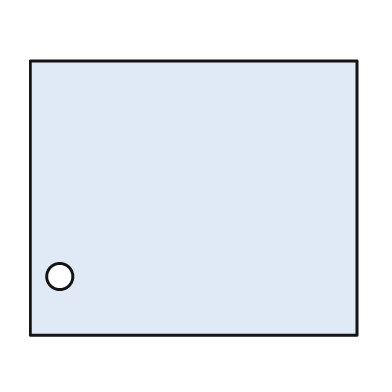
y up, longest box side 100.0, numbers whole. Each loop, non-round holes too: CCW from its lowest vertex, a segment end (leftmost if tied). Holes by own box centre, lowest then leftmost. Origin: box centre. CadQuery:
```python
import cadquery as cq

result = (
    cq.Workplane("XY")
    .moveTo(-50.0, -42.0)
    .lineTo(50.0, -42.0)
    .lineTo(50.0, 42.0)
    .lineTo(-50.0, 42.0)
    .close()
    .moveTo(-41.0, -24.0)
    .circle(4.0)
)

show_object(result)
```